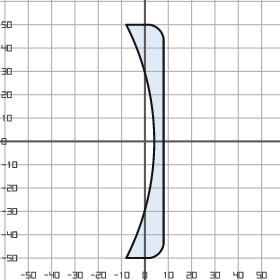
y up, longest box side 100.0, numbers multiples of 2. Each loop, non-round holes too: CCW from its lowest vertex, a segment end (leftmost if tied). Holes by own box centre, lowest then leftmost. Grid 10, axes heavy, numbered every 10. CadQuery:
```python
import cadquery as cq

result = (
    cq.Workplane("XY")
    .moveTo(-8.0, -50.0)
    .lineTo(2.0, -50.0)
    .threePointArc((6.0, -48.0), (8.0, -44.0))
    .lineTo(8.0, 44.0)
    .threePointArc((6.0, 48.0), (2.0, 50.0))
    .lineTo(-8.0, 50.0)
    .threePointArc((4.0, 0.0), (-8.0, -50.0))
    .close()
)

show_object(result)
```